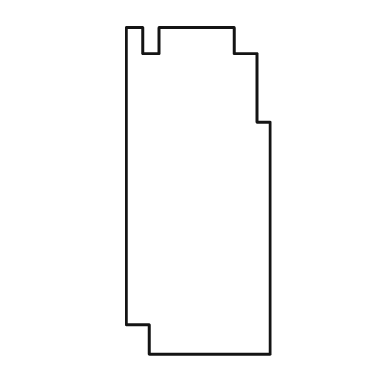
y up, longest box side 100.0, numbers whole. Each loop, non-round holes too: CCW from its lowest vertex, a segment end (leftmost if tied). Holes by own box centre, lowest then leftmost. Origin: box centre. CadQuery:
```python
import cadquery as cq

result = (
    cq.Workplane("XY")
    .moveTo(-15.0, -50.0)
    .lineTo(22.0, -50.0)
    .lineTo(22.0, 21.0)
    .lineTo(18.0, 21.0)
    .lineTo(18.0, 42.0)
    .lineTo(11.0, 42.0)
    .lineTo(11.0, 50.0)
    .lineTo(-12.0, 50.0)
    .lineTo(-12.0, 42.0)
    .lineTo(-17.0, 42.0)
    .lineTo(-17.0, 50.0)
    .lineTo(-22.0, 50.0)
    .lineTo(-22.0, -41.0)
    .lineTo(-15.0, -41.0)
    .close()
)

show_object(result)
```